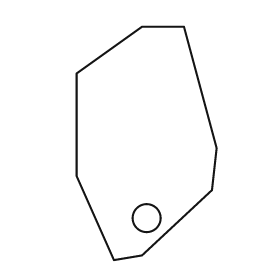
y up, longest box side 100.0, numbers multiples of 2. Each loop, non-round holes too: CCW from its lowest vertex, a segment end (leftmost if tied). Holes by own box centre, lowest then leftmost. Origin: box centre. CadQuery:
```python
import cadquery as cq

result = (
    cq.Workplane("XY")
    .moveTo(-14.0, -50.0)
    .lineTo(-2.0, -48.0)
    .lineTo(28.0, -20.0)
    .lineTo(30.0, -2.0)
    .lineTo(16.0, 50.0)
    .lineTo(-2.0, 50.0)
    .lineTo(-30.0, 30.0)
    .lineTo(-30.0, -14.0)
    .close()
    .moveTo(0.0, -32.0)
    .circle(6.0)
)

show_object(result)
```